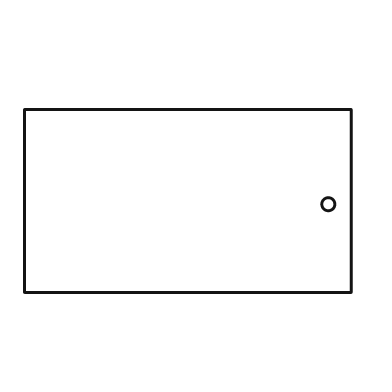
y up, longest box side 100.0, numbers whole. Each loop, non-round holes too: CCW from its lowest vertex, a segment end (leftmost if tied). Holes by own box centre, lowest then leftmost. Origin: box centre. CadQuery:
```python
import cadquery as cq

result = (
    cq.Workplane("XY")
    .moveTo(-50.0, -28.0)
    .lineTo(50.0, -28.0)
    .lineTo(50.0, 28.0)
    .lineTo(-50.0, 28.0)
    .close()
    .moveTo(43.0, -1.0)
    .circle(2.0)
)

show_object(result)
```